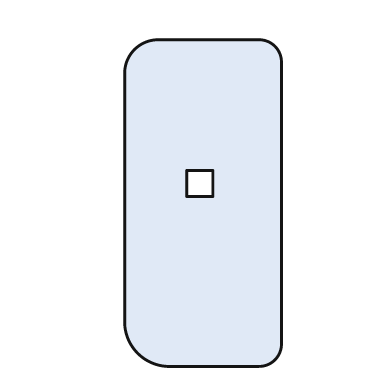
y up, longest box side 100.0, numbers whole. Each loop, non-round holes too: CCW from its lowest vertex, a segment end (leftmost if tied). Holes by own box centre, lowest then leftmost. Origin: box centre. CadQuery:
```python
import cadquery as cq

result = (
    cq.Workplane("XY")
    .moveTo(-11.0, -50.0)
    .lineTo(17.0, -50.0)
    .threePointArc((22.0, -48.0), (24.0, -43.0))
    .lineTo(24.0, 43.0)
    .threePointArc((22.0, 48.0), (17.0, 50.0))
    .lineTo(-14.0, 50.0)
    .threePointArc((-21.0, 47.0), (-24.0, 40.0))
    .lineTo(-24.0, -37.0)
    .threePointArc((-20.0, -46.0), (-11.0, -50.0))
    .close()
    .moveTo(-5.0, 2.0)
    .lineTo(3.0, 2.0)
    .lineTo(3.0, 10.0)
    .lineTo(-5.0, 10.0)
    .close()
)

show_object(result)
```